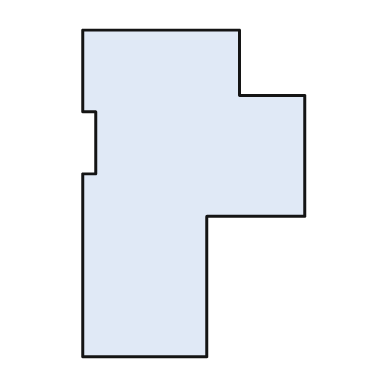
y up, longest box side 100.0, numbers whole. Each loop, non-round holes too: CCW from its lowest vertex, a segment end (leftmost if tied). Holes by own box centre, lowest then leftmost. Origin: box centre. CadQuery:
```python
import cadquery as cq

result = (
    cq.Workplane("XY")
    .moveTo(-34.0, -50.0)
    .lineTo(4.0, -50.0)
    .lineTo(4.0, -7.0)
    .lineTo(34.0, -7.0)
    .lineTo(34.0, 30.0)
    .lineTo(14.0, 30.0)
    .lineTo(14.0, 50.0)
    .lineTo(-34.0, 50.0)
    .lineTo(-34.0, 25.0)
    .lineTo(-30.0, 25.0)
    .lineTo(-30.0, 6.0)
    .lineTo(-34.0, 6.0)
    .close()
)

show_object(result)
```